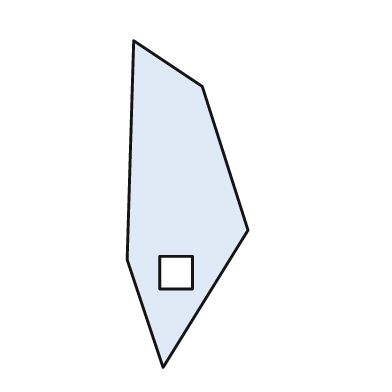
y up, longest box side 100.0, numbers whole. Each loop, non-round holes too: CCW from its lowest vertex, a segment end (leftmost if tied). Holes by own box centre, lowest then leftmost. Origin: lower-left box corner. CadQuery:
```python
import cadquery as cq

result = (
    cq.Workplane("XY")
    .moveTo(11.0, 0.0)
    .lineTo(37.0, 42.0)
    .lineTo(23.0, 86.0)
    .lineTo(2.0, 100.0)
    .lineTo(0.0, 33.0)
    .close()
    .moveTo(10.0, 24.0)
    .lineTo(20.0, 24.0)
    .lineTo(20.0, 34.0)
    .lineTo(10.0, 34.0)
    .close()
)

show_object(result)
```